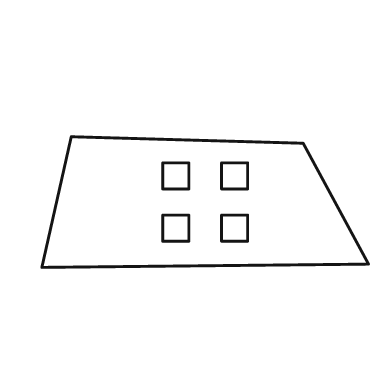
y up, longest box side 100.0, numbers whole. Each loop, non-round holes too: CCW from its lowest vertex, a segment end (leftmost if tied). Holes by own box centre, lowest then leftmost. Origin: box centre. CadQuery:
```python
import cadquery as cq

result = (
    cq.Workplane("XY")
    .moveTo(-50.0, -20.0)
    .lineTo(50.0, -19.0)
    .lineTo(30.0, 18.0)
    .lineTo(-41.0, 20.0)
    .close()
    .moveTo(-13.0, -12.0)
    .lineTo(-5.0, -12.0)
    .lineTo(-5.0, -4.0)
    .lineTo(-13.0, -4.0)
    .close()
    .moveTo(5.0, -12.0)
    .lineTo(13.0, -12.0)
    .lineTo(13.0, -4.0)
    .lineTo(5.0, -4.0)
    .close()
    .moveTo(-13.0, 4.0)
    .lineTo(-5.0, 4.0)
    .lineTo(-5.0, 12.0)
    .lineTo(-13.0, 12.0)
    .close()
    .moveTo(5.0, 4.0)
    .lineTo(13.0, 4.0)
    .lineTo(13.0, 12.0)
    .lineTo(5.0, 12.0)
    .close()
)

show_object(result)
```